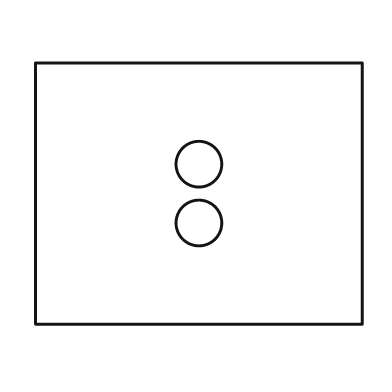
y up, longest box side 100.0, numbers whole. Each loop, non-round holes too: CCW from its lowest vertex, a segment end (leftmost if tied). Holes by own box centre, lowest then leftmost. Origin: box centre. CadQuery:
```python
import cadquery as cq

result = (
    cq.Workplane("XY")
    .moveTo(-50.0, -40.0)
    .lineTo(50.0, -40.0)
    .lineTo(50.0, 40.0)
    .lineTo(-50.0, 40.0)
    .close()
    .moveTo(0.0, -9.0)
    .circle(7.0)
    .moveTo(0.0, 9.0)
    .circle(7.0)
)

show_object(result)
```